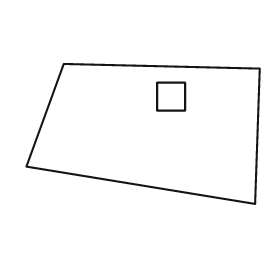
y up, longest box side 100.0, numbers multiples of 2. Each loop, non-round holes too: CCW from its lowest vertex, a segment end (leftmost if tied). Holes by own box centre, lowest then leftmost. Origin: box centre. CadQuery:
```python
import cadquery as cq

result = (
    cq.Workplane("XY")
    .moveTo(48.0, -30.0)
    .lineTo(50.0, 28.0)
    .lineTo(-34.0, 30.0)
    .lineTo(-50.0, -14.0)
    .close()
    .moveTo(6.0, 10.0)
    .lineTo(18.0, 10.0)
    .lineTo(18.0, 22.0)
    .lineTo(6.0, 22.0)
    .close()
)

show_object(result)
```